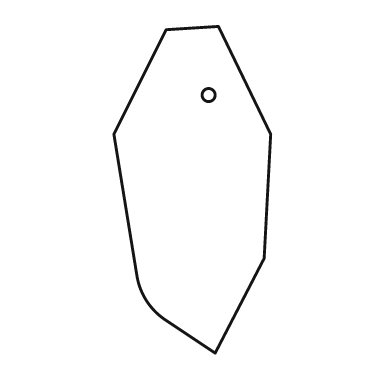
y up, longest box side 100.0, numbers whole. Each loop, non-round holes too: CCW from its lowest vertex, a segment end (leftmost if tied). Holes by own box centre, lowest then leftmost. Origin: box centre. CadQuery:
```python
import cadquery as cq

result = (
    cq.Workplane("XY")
    .moveTo(7.0, -50.0)
    .lineTo(22.0, -21.0)
    .lineTo(24.0, 17.0)
    .lineTo(8.0, 50.0)
    .lineTo(-8.0, 49.0)
    .lineTo(-24.0, 17.0)
    .lineTo(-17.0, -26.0)
    .threePointArc((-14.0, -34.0), (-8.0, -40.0))
    .close()
    .moveTo(5.0, 29.0)
    .circle(2.0)
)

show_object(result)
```